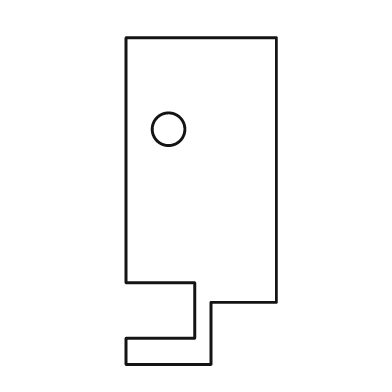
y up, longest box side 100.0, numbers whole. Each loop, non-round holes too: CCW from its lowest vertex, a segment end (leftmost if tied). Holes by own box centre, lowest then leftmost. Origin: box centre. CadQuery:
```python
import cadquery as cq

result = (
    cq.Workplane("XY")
    .moveTo(-23.0, -50.0)
    .lineTo(3.0, -50.0)
    .lineTo(3.0, -31.0)
    .lineTo(23.0, -31.0)
    .lineTo(23.0, 50.0)
    .lineTo(-23.0, 50.0)
    .lineTo(-23.0, -25.0)
    .lineTo(-2.0, -25.0)
    .lineTo(-2.0, -42.0)
    .lineTo(-23.0, -42.0)
    .close()
    .moveTo(-10.0, 22.0)
    .circle(5.0)
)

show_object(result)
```